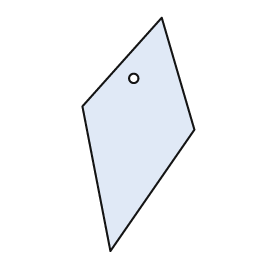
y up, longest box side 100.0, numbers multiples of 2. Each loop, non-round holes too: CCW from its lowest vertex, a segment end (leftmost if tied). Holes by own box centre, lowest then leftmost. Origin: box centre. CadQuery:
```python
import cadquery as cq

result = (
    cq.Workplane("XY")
    .moveTo(-12.0, -50.0)
    .lineTo(24.0, 2.0)
    .lineTo(10.0, 50.0)
    .lineTo(-24.0, 12.0)
    .close()
    .moveTo(-2.0, 24.0)
    .circle(2.0)
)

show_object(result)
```